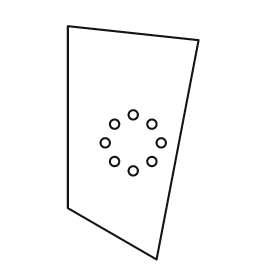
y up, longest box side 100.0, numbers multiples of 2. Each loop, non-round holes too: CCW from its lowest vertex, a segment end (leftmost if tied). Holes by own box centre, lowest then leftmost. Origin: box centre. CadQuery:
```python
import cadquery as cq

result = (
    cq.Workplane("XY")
    .moveTo(10.0, -50.0)
    .lineTo(28.0, 44.0)
    .lineTo(-28.0, 50.0)
    .lineTo(-28.0, -28.0)
    .close()
    .moveTo(0.0, -12.0)
    .circle(2.0)
    .moveTo(-8.0, -8.0)
    .circle(2.0)
    .moveTo(8.0, -8.0)
    .circle(2.0)
    .moveTo(-12.0, 0.0)
    .circle(2.0)
    .moveTo(12.0, 0.0)
    .circle(2.0)
    .moveTo(-8.0, 8.0)
    .circle(2.0)
    .moveTo(8.0, 8.0)
    .circle(2.0)
    .moveTo(0.0, 12.0)
    .circle(2.0)
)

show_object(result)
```